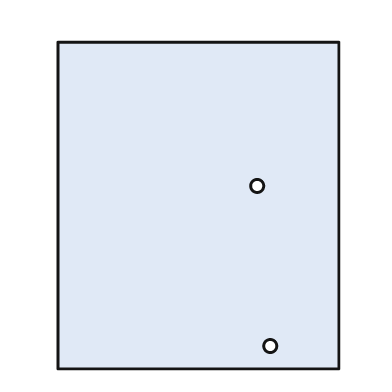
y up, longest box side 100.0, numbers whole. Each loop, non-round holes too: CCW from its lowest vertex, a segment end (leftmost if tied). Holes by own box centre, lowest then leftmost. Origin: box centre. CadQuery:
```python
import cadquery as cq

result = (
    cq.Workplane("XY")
    .moveTo(-43.0, -50.0)
    .lineTo(43.0, -50.0)
    .lineTo(43.0, 50.0)
    .lineTo(-43.0, 50.0)
    .close()
    .moveTo(22.0, -43.0)
    .circle(2.0)
    .moveTo(18.0, 6.0)
    .circle(2.0)
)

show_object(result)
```